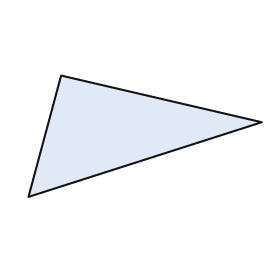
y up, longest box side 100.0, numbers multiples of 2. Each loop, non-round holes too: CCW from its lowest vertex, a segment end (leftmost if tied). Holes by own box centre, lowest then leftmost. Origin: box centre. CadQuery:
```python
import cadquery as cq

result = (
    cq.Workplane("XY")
    .moveTo(-50.0, -26.0)
    .lineTo(50.0, 6.0)
    .lineTo(-36.0, 26.0)
    .close()
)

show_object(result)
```